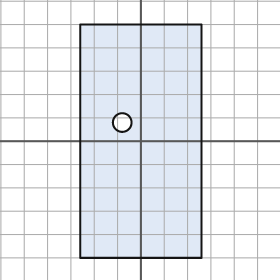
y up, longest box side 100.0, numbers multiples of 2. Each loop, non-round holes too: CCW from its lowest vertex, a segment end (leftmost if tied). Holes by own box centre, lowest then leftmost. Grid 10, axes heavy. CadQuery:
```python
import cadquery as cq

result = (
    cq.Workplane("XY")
    .moveTo(-26.0, -50.0)
    .lineTo(26.0, -50.0)
    .lineTo(26.0, 50.0)
    .lineTo(-26.0, 50.0)
    .close()
    .moveTo(-8.0, 8.0)
    .circle(4.0)
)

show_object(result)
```